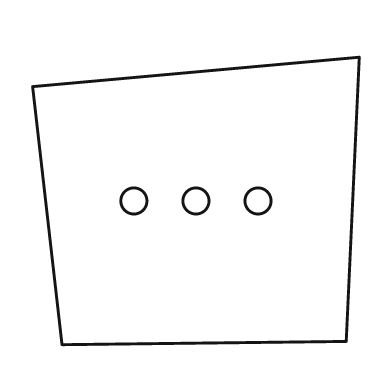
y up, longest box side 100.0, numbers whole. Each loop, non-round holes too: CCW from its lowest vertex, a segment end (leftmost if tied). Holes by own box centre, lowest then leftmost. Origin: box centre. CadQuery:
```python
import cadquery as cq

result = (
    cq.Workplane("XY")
    .moveTo(-41.0, -44.0)
    .lineTo(46.0, -43.0)
    .lineTo(50.0, 44.0)
    .lineTo(-50.0, 35.0)
    .close()
    .moveTo(-19.0, 0.0)
    .circle(4.0)
    .moveTo(0.0, 0.0)
    .circle(4.0)
    .moveTo(19.0, 0.0)
    .circle(4.0)
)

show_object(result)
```